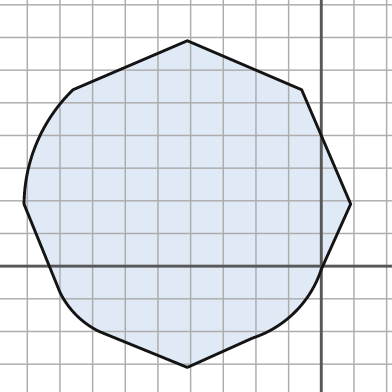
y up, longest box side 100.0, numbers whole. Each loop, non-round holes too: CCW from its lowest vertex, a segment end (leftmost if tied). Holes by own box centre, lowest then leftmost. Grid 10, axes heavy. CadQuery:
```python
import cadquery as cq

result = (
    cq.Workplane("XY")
    .moveTo(-41.0, -31.0)
    .lineTo(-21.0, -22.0)
    .threePointArc((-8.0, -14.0), (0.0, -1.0))
    .lineTo(9.0, 19.0)
    .lineTo(-6.0, 54.0)
    .lineTo(-41.0, 69.0)
    .lineTo(-76.0, 54.0)
    .threePointArc((-87.0, 38.0), (-91.0, 19.0))
    .lineTo(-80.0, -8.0)
    .threePointArc((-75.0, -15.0), (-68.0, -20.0))
    .close()
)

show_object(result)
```